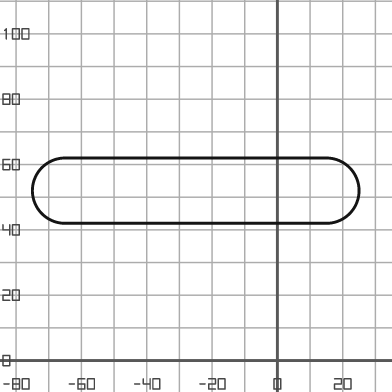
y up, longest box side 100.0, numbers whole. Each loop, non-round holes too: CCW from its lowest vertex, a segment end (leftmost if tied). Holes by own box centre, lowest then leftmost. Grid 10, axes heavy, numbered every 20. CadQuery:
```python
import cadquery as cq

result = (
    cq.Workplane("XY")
    .moveTo(-65.0, 42.0)
    .lineTo(15.0, 42.0)
    .threePointArc((25.0, 52.0), (15.0, 62.0))
    .lineTo(-65.0, 62.0)
    .threePointArc((-75.0, 52.0), (-65.0, 42.0))
    .close()
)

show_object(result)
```